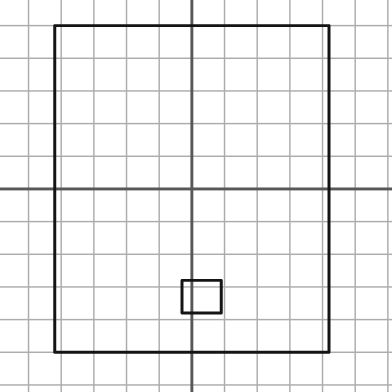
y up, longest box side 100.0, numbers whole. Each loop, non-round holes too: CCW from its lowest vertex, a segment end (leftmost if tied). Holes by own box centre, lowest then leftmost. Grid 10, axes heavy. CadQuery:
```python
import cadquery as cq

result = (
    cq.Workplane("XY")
    .moveTo(-42.0, -50.0)
    .lineTo(42.0, -50.0)
    .lineTo(42.0, 50.0)
    .lineTo(-42.0, 50.0)
    .close()
    .moveTo(-3.0, -38.0)
    .lineTo(9.0, -38.0)
    .lineTo(9.0, -28.0)
    .lineTo(-3.0, -28.0)
    .close()
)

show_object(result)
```